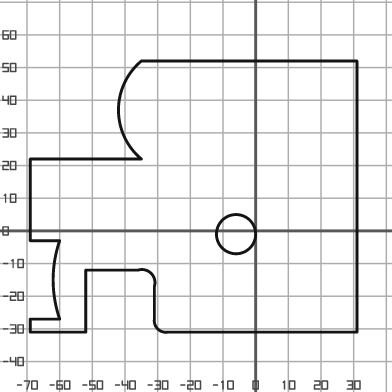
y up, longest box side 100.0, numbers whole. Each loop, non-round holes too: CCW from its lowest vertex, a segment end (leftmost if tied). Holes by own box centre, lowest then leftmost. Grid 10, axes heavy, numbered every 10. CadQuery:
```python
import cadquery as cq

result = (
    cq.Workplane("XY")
    .moveTo(-69.0, -31.0)
    .lineTo(-52.0, -31.0)
    .lineTo(-52.0, -12.0)
    .lineTo(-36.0, -12.0)
    .threePointArc((-32.0, -13.0), (-31.0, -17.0))
    .lineTo(-31.0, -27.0)
    .threePointArc((-30.0, -30.0), (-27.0, -31.0))
    .lineTo(31.0, -31.0)
    .lineTo(31.0, 52.0)
    .lineTo(-35.0, 52.0)
    .threePointArc((-42.0, 37.0), (-35.0, 22.0))
    .lineTo(-69.0, 22.0)
    .lineTo(-69.0, -3.0)
    .lineTo(-60.0, -3.0)
    .threePointArc((-62.0, -15.0), (-60.0, -27.0))
    .lineTo(-69.0, -27.0)
    .close()
    .moveTo(-6.0, -1.0)
    .circle(6.0)
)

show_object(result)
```